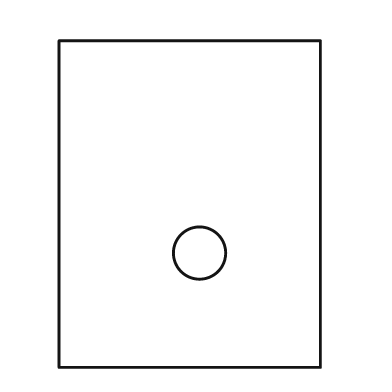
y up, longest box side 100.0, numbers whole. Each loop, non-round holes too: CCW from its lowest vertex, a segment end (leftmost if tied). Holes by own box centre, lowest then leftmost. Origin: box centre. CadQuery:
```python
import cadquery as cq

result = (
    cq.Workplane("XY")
    .moveTo(-40.0, -50.0)
    .lineTo(40.0, -50.0)
    .lineTo(40.0, 50.0)
    .lineTo(-40.0, 50.0)
    .close()
    .moveTo(3.0, -15.0)
    .circle(8.0)
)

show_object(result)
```